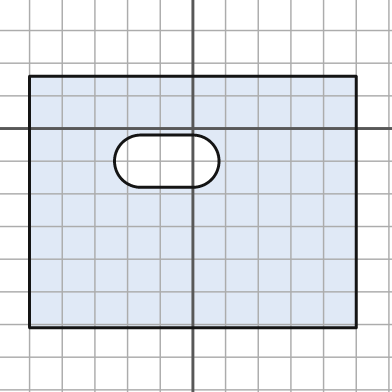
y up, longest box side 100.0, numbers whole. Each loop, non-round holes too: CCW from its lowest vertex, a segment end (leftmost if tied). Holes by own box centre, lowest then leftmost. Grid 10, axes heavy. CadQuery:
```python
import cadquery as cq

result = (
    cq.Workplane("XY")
    .moveTo(-50.0, -61.0)
    .lineTo(50.0, -61.0)
    .lineTo(50.0, 16.0)
    .lineTo(-50.0, 16.0)
    .close()
    .moveTo(-16.0, -18.0)
    .lineTo(0.0, -18.0)
    .threePointArc((8.0, -10.0), (0.0, -2.0))
    .lineTo(-16.0, -2.0)
    .threePointArc((-24.0, -10.0), (-16.0, -18.0))
    .close()
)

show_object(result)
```